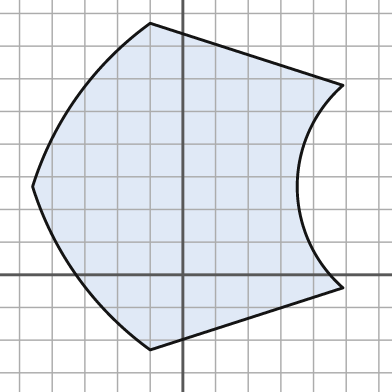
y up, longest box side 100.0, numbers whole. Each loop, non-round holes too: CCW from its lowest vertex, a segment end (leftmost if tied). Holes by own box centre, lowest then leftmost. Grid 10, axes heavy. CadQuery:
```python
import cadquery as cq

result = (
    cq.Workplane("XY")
    .moveTo(-10.0, -23.0)
    .lineTo(49.0, -4.0)
    .threePointArc((35.0, 27.0), (49.0, 58.0))
    .lineTo(-10.0, 77.0)
    .threePointArc((-32.0, 55.0), (-46.0, 27.0))
    .threePointArc((-32.0, -1.0), (-10.0, -23.0))
    .close()
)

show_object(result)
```